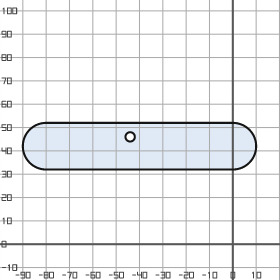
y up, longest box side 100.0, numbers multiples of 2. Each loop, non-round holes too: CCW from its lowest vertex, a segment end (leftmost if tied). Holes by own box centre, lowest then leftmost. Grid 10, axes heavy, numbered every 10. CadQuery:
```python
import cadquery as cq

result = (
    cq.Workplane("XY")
    .moveTo(-80.0, 32.0)
    .lineTo(0.0, 32.0)
    .threePointArc((10.0, 42.0), (0.0, 52.0))
    .lineTo(-80.0, 52.0)
    .threePointArc((-90.0, 42.0), (-80.0, 32.0))
    .close()
    .moveTo(-44.0, 46.0)
    .circle(2.0)
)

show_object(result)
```